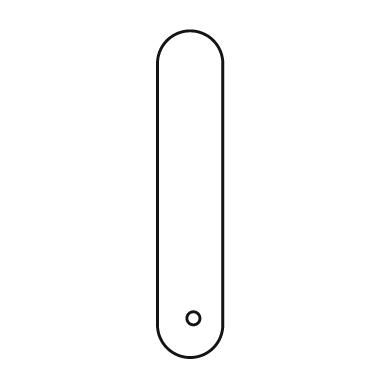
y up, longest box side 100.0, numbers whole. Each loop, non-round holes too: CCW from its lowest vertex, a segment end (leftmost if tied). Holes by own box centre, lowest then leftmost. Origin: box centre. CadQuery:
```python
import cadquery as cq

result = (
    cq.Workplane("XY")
    .moveTo(-10.0, -40.0)
    .threePointArc((0.0, -50.0), (10.0, -40.0))
    .lineTo(10.0, 40.0)
    .threePointArc((0.0, 50.0), (-10.0, 40.0))
    .close()
    .moveTo(1.0, -38.0)
    .circle(2.0)
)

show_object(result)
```